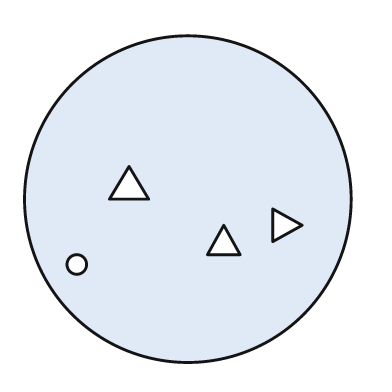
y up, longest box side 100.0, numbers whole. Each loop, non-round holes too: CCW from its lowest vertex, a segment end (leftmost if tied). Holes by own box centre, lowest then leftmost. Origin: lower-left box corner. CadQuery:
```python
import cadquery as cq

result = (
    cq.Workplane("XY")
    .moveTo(50.0, 50.0)
    .circle(50.0)
    .moveTo(16.0, 30.0)
    .circle(3.0)
    .moveTo(56.0, 33.0)
    .lineTo(66.0, 33.0)
    .lineTo(61.0, 42.0)
    .close()
    .moveTo(76.0, 37.0)
    .lineTo(85.0, 42.0)
    .lineTo(76.0, 47.0)
    .close()
    .moveTo(26.0, 50.0)
    .lineTo(38.0, 50.0)
    .lineTo(32.0, 60.0)
    .close()
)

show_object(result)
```